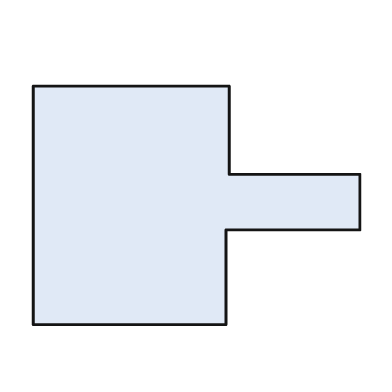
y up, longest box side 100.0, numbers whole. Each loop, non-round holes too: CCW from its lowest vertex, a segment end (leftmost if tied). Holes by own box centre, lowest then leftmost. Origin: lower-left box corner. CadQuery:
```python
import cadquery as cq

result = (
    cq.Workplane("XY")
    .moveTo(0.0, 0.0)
    .lineTo(59.0, 0.0)
    .lineTo(59.0, 29.0)
    .lineTo(100.0, 29.0)
    .lineTo(100.0, 46.0)
    .lineTo(60.0, 46.0)
    .lineTo(60.0, 73.0)
    .lineTo(0.0, 73.0)
    .close()
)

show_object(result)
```